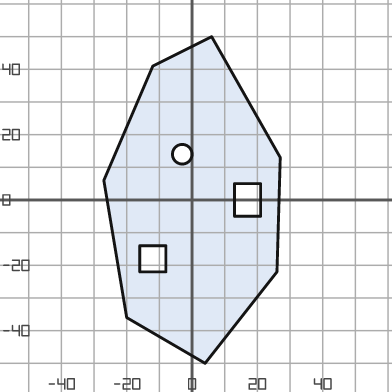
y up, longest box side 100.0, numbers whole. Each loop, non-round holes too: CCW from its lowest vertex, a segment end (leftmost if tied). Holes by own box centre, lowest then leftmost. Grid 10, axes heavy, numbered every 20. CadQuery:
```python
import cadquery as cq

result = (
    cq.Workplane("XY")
    .moveTo(4.0, -50.0)
    .lineTo(26.0, -22.0)
    .lineTo(27.0, 13.0)
    .lineTo(6.0, 50.0)
    .lineTo(-12.0, 41.0)
    .lineTo(-27.0, 6.0)
    .lineTo(-20.0, -36.0)
    .close()
    .moveTo(-16.0, -22.0)
    .lineTo(-8.0, -22.0)
    .lineTo(-8.0, -14.0)
    .lineTo(-16.0, -14.0)
    .close()
    .moveTo(13.0, -5.0)
    .lineTo(21.0, -5.0)
    .lineTo(21.0, 5.0)
    .lineTo(13.0, 5.0)
    .close()
    .moveTo(-3.0, 14.0)
    .circle(3.0)
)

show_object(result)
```